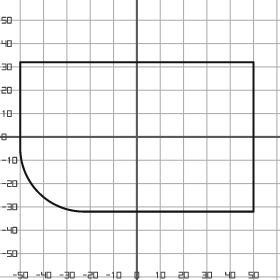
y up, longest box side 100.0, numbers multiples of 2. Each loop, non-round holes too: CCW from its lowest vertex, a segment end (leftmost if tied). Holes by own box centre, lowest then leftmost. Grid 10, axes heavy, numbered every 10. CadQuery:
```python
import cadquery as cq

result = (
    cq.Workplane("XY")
    .moveTo(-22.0, -32.0)
    .lineTo(50.0, -32.0)
    .lineTo(50.0, 32.0)
    .lineTo(-50.0, 32.0)
    .lineTo(-50.0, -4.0)
    .threePointArc((-42.0, -24.0), (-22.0, -32.0))
    .close()
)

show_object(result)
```